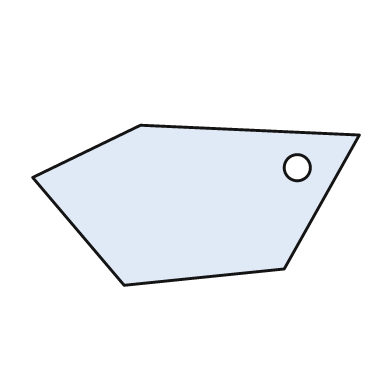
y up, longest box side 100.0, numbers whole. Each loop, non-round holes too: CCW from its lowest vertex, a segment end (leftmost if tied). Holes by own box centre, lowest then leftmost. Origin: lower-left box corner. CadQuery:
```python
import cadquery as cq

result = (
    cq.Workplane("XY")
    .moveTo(28.0, 0.0)
    .lineTo(77.0, 5.0)
    .lineTo(100.0, 46.0)
    .lineTo(33.0, 49.0)
    .lineTo(0.0, 33.0)
    .close()
    .moveTo(81.0, 36.0)
    .circle(4.0)
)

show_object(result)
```